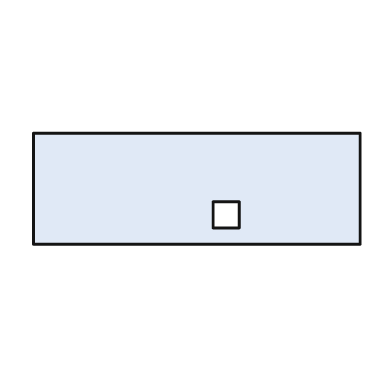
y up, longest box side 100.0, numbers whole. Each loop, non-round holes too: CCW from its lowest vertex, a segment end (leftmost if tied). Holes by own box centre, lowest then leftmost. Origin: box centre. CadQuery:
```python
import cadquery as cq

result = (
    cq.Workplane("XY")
    .moveTo(-50.0, -17.0)
    .lineTo(50.0, -17.0)
    .lineTo(50.0, 17.0)
    .lineTo(-50.0, 17.0)
    .close()
    .moveTo(5.0, -12.0)
    .lineTo(13.0, -12.0)
    .lineTo(13.0, -4.0)
    .lineTo(5.0, -4.0)
    .close()
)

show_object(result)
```